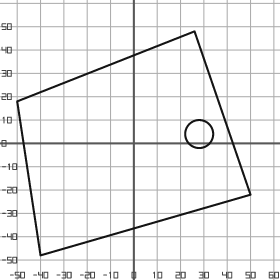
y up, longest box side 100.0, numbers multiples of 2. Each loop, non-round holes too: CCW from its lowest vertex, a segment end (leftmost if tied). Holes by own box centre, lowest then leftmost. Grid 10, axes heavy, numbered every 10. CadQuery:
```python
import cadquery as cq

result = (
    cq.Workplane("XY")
    .moveTo(-40.0, -48.0)
    .lineTo(50.0, -22.0)
    .lineTo(26.0, 48.0)
    .lineTo(-50.0, 18.0)
    .close()
    .moveTo(28.0, 4.0)
    .circle(6.0)
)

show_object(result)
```